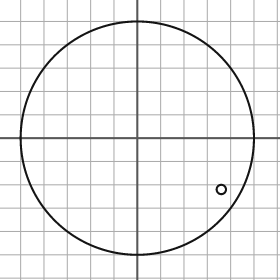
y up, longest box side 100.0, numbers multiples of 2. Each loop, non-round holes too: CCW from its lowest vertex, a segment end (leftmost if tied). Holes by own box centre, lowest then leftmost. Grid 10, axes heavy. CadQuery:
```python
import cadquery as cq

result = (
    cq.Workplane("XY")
    .moveTo(0.0, 0.0)
    .circle(50.0)
    .moveTo(36.0, -22.0)
    .circle(2.0)
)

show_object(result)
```